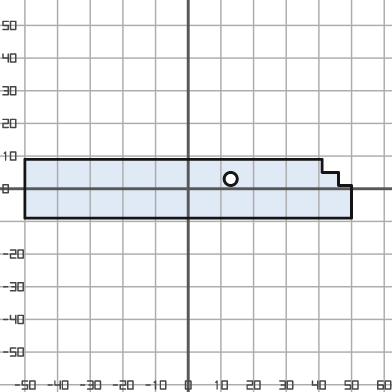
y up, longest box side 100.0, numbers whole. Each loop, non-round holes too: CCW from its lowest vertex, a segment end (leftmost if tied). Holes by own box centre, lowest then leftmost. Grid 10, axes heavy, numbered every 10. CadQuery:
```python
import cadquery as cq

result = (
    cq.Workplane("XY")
    .moveTo(-50.0, -9.0)
    .lineTo(50.0, -9.0)
    .lineTo(50.0, 1.0)
    .lineTo(46.0, 1.0)
    .lineTo(46.0, 5.0)
    .lineTo(41.0, 5.0)
    .lineTo(41.0, 9.0)
    .lineTo(-50.0, 9.0)
    .close()
    .moveTo(13.0, 3.0)
    .circle(2.0)
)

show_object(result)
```